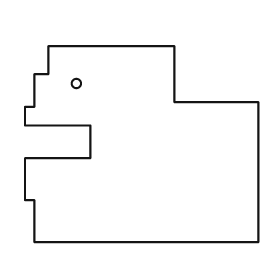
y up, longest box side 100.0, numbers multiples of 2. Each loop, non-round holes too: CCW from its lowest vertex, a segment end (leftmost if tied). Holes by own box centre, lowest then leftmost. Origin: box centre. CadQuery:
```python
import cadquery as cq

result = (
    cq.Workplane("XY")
    .moveTo(-46.0, -42.0)
    .lineTo(50.0, -42.0)
    .lineTo(50.0, 18.0)
    .lineTo(14.0, 18.0)
    .lineTo(14.0, 42.0)
    .lineTo(-40.0, 42.0)
    .lineTo(-40.0, 30.0)
    .lineTo(-46.0, 30.0)
    .lineTo(-46.0, 16.0)
    .lineTo(-50.0, 16.0)
    .lineTo(-50.0, 8.0)
    .lineTo(-22.0, 8.0)
    .lineTo(-22.0, -6.0)
    .lineTo(-50.0, -6.0)
    .lineTo(-50.0, -24.0)
    .lineTo(-46.0, -24.0)
    .close()
    .moveTo(-28.0, 26.0)
    .circle(2.0)
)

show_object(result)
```